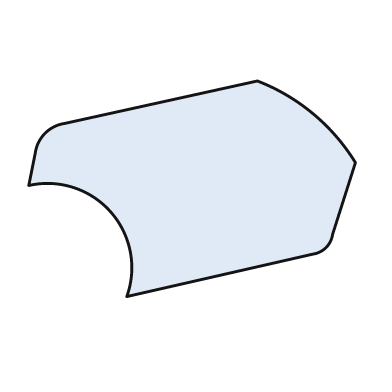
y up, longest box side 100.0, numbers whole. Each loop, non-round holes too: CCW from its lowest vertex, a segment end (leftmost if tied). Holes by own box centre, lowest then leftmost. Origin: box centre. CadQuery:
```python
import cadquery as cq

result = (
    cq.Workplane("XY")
    .moveTo(-20.0, -33.0)
    .lineTo(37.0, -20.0)
    .threePointArc((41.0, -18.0), (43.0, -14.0))
    .lineTo(50.0, 8.0)
    .threePointArc((37.0, 23.0), (20.0, 33.0))
    .lineTo(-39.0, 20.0)
    .threePointArc((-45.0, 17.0), (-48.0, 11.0))
    .lineTo(-50.0, 1.0)
    .threePointArc((-25.0, -7.0), (-20.0, -33.0))
    .close()
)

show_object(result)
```